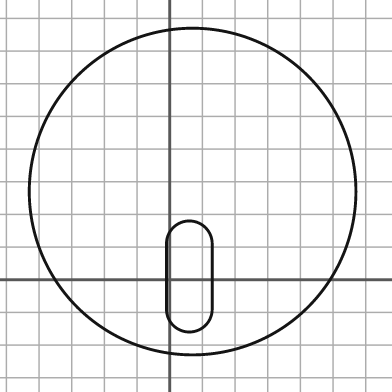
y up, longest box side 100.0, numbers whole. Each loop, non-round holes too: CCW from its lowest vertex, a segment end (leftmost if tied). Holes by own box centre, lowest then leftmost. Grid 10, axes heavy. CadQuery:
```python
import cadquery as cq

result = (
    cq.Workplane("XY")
    .moveTo(7.0, 27.0)
    .circle(50.0)
    .moveTo(-1.0, -9.0)
    .threePointArc((6.0, -16.0), (13.0, -9.0))
    .lineTo(13.0, 11.0)
    .threePointArc((6.0, 18.0), (-1.0, 11.0))
    .close()
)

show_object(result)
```